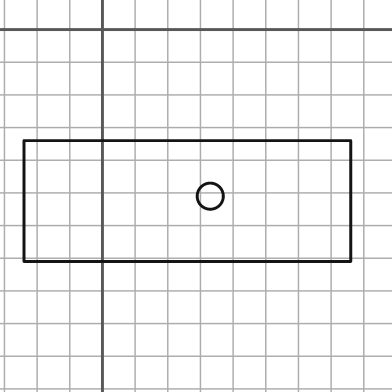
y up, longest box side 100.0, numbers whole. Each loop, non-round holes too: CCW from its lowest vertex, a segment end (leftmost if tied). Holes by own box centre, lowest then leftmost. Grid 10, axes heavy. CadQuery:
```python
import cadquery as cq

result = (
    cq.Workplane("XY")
    .moveTo(-24.0, -71.0)
    .lineTo(76.0, -71.0)
    .lineTo(76.0, -34.0)
    .lineTo(-24.0, -34.0)
    .close()
    .moveTo(33.0, -51.0)
    .circle(4.0)
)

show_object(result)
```